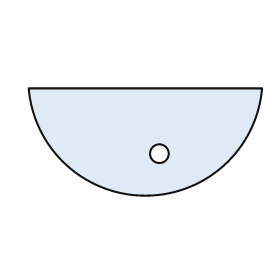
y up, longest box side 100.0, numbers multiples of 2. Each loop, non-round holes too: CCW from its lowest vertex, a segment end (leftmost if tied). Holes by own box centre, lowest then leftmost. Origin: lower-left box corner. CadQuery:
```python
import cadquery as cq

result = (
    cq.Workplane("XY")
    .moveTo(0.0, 46.0)
    .threePointArc((50.0, 0.0), (100.0, 46.0))
    .close()
    .moveTo(56.0, 18.0)
    .circle(4.0)
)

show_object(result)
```